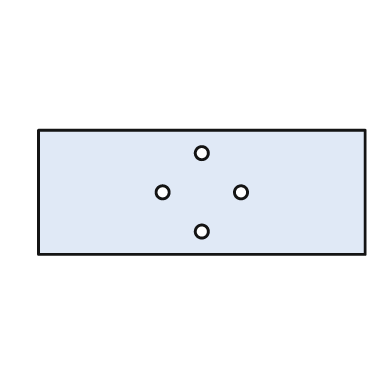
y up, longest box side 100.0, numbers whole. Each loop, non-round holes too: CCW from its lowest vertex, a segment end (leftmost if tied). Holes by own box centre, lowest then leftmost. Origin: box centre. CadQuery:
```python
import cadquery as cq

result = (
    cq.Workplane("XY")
    .moveTo(-50.0, -19.0)
    .lineTo(50.0, -19.0)
    .lineTo(50.0, 19.0)
    .lineTo(-50.0, 19.0)
    .close()
    .moveTo(0.0, -12.0)
    .circle(2.0)
    .moveTo(-12.0, 0.0)
    .circle(2.0)
    .moveTo(12.0, 0.0)
    .circle(2.0)
    .moveTo(0.0, 12.0)
    .circle(2.0)
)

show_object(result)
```